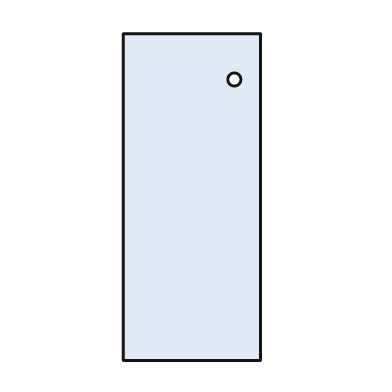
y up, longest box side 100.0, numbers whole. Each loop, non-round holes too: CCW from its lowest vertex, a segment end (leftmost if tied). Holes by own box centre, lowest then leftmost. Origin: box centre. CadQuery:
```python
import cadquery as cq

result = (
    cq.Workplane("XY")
    .moveTo(-21.0, -50.0)
    .lineTo(21.0, -50.0)
    .lineTo(21.0, 50.0)
    .lineTo(-21.0, 50.0)
    .close()
    .moveTo(13.0, 36.0)
    .circle(2.0)
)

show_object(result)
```